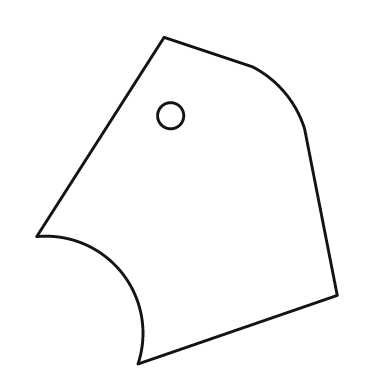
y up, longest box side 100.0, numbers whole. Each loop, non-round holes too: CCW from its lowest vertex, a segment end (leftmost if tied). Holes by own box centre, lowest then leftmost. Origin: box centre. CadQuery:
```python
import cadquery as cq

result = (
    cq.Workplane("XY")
    .moveTo(-15.0, -50.0)
    .lineTo(46.0, -29.0)
    .lineTo(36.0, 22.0)
    .threePointArc((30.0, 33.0), (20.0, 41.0))
    .lineTo(-7.0, 50.0)
    .lineTo(-46.0, -11.0)
    .threePointArc((-20.0, -22.0), (-15.0, -50.0))
    .close()
    .moveTo(-5.0, 26.0)
    .circle(4.0)
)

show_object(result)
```